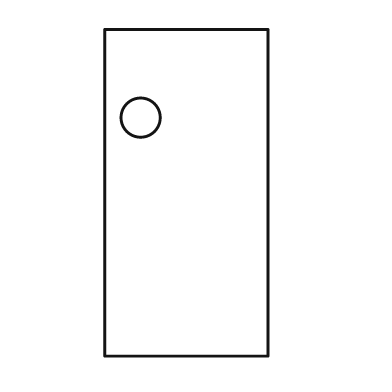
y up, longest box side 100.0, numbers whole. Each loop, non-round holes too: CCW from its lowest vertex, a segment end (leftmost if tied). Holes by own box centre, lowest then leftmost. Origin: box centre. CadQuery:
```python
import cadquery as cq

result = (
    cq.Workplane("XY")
    .moveTo(-25.0, -50.0)
    .lineTo(25.0, -50.0)
    .lineTo(25.0, 50.0)
    .lineTo(-25.0, 50.0)
    .close()
    .moveTo(-14.0, 23.0)
    .circle(6.0)
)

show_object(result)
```